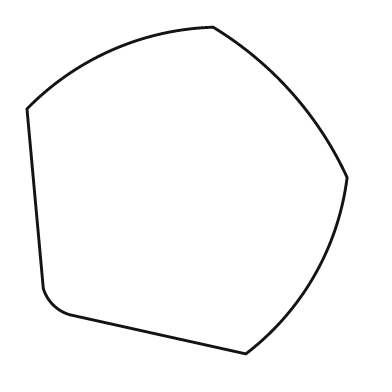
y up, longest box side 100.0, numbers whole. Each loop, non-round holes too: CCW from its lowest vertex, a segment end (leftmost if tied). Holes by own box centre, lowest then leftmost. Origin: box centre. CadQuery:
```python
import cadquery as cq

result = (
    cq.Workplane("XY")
    .moveTo(18.0, -50.0)
    .threePointArc((39.0, -26.0), (49.0, 4.0))
    .threePointArc((32.0, 30.0), (8.0, 50.0))
    .threePointArc((-23.0, 43.0), (-49.0, 25.0))
    .lineTo(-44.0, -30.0)
    .threePointArc((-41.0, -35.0), (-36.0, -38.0))
    .close()
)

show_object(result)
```